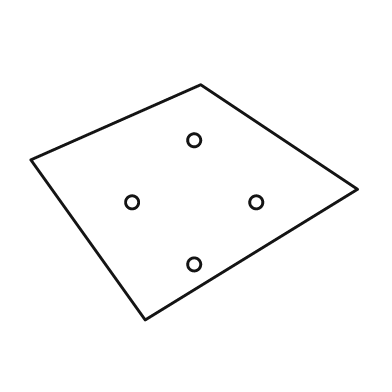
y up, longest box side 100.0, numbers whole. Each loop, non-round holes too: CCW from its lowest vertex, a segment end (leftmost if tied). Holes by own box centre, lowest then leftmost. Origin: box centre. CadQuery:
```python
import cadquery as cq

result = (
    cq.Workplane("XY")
    .moveTo(-15.0, -36.0)
    .lineTo(50.0, 4.0)
    .lineTo(2.0, 36.0)
    .lineTo(-50.0, 13.0)
    .close()
    .moveTo(0.0, -19.0)
    .circle(2.0)
    .moveTo(-19.0, 0.0)
    .circle(2.0)
    .moveTo(19.0, 0.0)
    .circle(2.0)
    .moveTo(0.0, 19.0)
    .circle(2.0)
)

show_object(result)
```